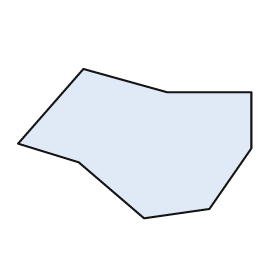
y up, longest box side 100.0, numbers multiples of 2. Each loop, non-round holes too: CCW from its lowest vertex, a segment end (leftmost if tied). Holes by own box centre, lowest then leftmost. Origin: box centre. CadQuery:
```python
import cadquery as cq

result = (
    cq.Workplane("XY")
    .moveTo(4.0, -32.0)
    .lineTo(32.0, -28.0)
    .lineTo(50.0, -2.0)
    .lineTo(50.0, 22.0)
    .lineTo(14.0, 22.0)
    .lineTo(-22.0, 32.0)
    .lineTo(-50.0, 0.0)
    .lineTo(-24.0, -8.0)
    .close()
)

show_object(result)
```